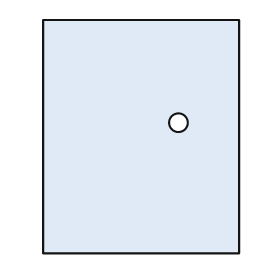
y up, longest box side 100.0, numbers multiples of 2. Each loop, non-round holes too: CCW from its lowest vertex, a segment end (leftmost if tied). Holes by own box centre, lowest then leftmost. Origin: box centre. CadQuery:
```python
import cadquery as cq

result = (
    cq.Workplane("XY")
    .moveTo(-42.0, -50.0)
    .lineTo(42.0, -50.0)
    .lineTo(42.0, 50.0)
    .lineTo(-42.0, 50.0)
    .close()
    .moveTo(16.0, 6.0)
    .circle(4.0)
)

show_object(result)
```